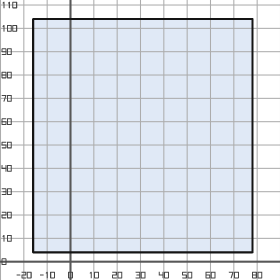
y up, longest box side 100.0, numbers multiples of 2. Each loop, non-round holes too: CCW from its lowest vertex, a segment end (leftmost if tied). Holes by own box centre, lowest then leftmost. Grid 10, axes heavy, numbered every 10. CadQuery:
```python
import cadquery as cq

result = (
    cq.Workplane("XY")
    .moveTo(-16.0, 4.0)
    .lineTo(78.0, 4.0)
    .lineTo(78.0, 104.0)
    .lineTo(-16.0, 104.0)
    .close()
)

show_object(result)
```